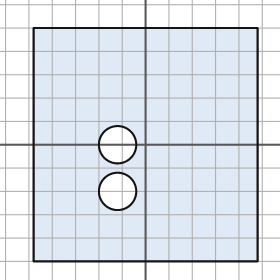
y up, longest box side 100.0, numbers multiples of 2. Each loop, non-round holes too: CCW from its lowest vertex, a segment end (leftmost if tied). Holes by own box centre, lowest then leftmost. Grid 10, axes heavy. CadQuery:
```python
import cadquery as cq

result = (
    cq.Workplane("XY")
    .moveTo(-48.0, -50.0)
    .lineTo(48.0, -50.0)
    .lineTo(48.0, 50.0)
    .lineTo(-48.0, 50.0)
    .close()
    .moveTo(-12.0, -20.0)
    .circle(8.0)
    .moveTo(-12.0, 0.0)
    .circle(8.0)
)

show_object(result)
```